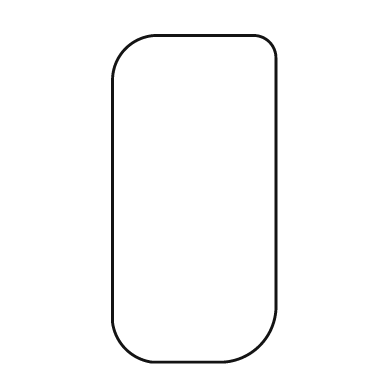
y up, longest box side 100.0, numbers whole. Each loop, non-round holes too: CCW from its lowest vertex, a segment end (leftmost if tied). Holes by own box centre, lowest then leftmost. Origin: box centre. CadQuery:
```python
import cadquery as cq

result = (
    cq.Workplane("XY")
    .moveTo(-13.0, -50.0)
    .lineTo(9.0, -50.0)
    .threePointArc((20.0, -45.0), (25.0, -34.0))
    .lineTo(25.0, 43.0)
    .threePointArc((23.0, 48.0), (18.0, 50.0))
    .lineTo(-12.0, 50.0)
    .threePointArc((-21.0, 46.0), (-25.0, 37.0))
    .lineTo(-25.0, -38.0)
    .threePointArc((-21.0, -46.0), (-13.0, -50.0))
    .close()
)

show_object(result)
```